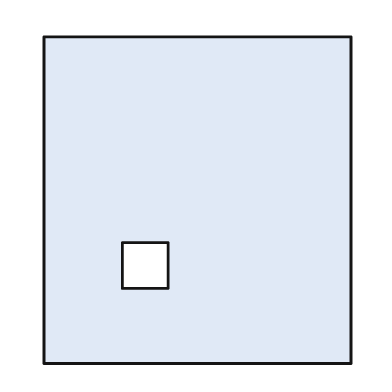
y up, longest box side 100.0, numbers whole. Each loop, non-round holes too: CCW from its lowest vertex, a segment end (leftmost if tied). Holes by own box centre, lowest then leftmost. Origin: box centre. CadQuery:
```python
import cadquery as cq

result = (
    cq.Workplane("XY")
    .moveTo(-47.0, -50.0)
    .lineTo(47.0, -50.0)
    .lineTo(47.0, 50.0)
    .lineTo(-47.0, 50.0)
    .close()
    .moveTo(-23.0, -27.0)
    .lineTo(-9.0, -27.0)
    .lineTo(-9.0, -13.0)
    .lineTo(-23.0, -13.0)
    .close()
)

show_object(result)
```